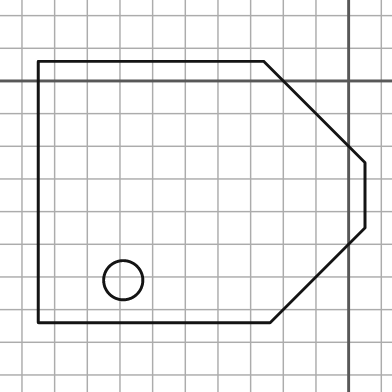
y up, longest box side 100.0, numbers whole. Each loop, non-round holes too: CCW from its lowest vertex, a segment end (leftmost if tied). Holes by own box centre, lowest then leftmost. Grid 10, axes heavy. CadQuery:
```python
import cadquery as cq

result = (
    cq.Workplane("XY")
    .moveTo(-95.0, -74.0)
    .lineTo(-24.0, -74.0)
    .lineTo(5.0, -45.0)
    .lineTo(5.0, -25.0)
    .lineTo(-26.0, 6.0)
    .lineTo(-95.0, 6.0)
    .close()
    .moveTo(-69.0, -61.0)
    .circle(6.0)
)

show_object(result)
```